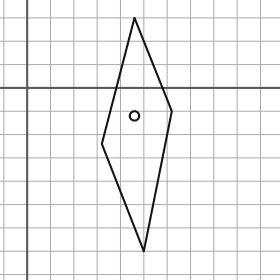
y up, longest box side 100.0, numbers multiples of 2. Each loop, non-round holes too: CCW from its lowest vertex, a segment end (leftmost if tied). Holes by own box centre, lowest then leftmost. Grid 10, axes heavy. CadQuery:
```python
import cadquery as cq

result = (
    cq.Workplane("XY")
    .moveTo(50.0, -70.0)
    .lineTo(62.0, -10.0)
    .lineTo(46.0, 30.0)
    .lineTo(32.0, -24.0)
    .close()
    .moveTo(46.0, -12.0)
    .circle(2.0)
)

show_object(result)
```